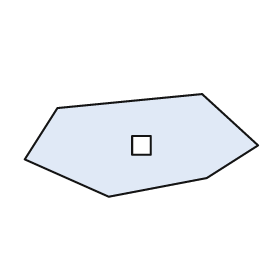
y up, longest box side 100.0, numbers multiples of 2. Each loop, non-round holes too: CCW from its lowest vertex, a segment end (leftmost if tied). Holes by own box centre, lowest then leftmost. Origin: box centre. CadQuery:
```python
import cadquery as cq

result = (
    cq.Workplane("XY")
    .moveTo(-14.0, -22.0)
    .lineTo(28.0, -14.0)
    .lineTo(50.0, 0.0)
    .lineTo(26.0, 22.0)
    .lineTo(-36.0, 16.0)
    .lineTo(-50.0, -6.0)
    .close()
    .moveTo(-4.0, -4.0)
    .lineTo(4.0, -4.0)
    .lineTo(4.0, 4.0)
    .lineTo(-4.0, 4.0)
    .close()
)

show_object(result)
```